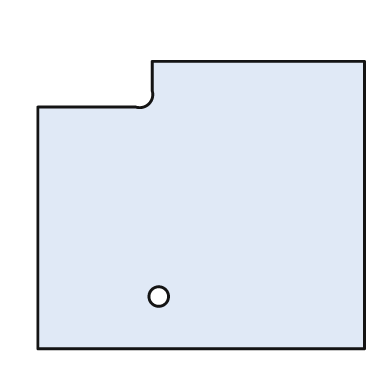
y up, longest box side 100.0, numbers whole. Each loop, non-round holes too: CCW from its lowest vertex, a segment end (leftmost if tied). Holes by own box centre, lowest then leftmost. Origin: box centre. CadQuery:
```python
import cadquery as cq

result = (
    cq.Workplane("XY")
    .moveTo(-50.0, -44.0)
    .lineTo(50.0, -44.0)
    .lineTo(50.0, 44.0)
    .lineTo(-15.0, 44.0)
    .lineTo(-15.0, 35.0)
    .threePointArc((-16.0, 31.0), (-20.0, 30.0))
    .lineTo(-50.0, 30.0)
    .close()
    .moveTo(-13.0, -28.0)
    .circle(3.0)
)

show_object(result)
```